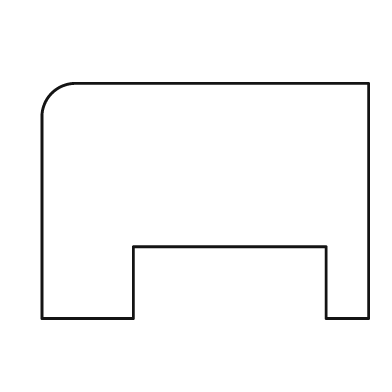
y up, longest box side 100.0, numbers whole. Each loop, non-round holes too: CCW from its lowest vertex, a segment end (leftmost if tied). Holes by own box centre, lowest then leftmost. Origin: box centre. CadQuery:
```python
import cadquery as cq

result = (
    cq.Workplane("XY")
    .moveTo(-50.0, -36.0)
    .lineTo(-22.0, -36.0)
    .lineTo(-22.0, -14.0)
    .lineTo(37.0, -14.0)
    .lineTo(37.0, -36.0)
    .lineTo(50.0, -36.0)
    .lineTo(50.0, 36.0)
    .lineTo(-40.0, 36.0)
    .threePointArc((-47.0, 33.0), (-50.0, 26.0))
    .close()
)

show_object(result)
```